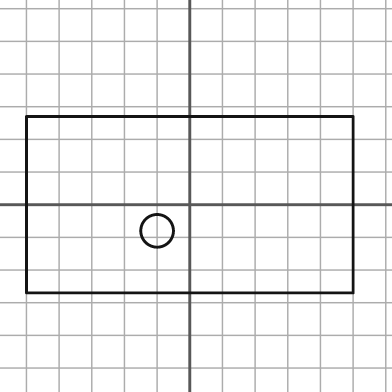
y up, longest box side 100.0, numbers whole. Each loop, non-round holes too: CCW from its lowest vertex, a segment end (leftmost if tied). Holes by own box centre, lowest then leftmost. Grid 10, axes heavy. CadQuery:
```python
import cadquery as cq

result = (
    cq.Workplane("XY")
    .moveTo(-50.0, -27.0)
    .lineTo(50.0, -27.0)
    .lineTo(50.0, 27.0)
    .lineTo(-50.0, 27.0)
    .close()
    .moveTo(-10.0, -8.0)
    .circle(5.0)
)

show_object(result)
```